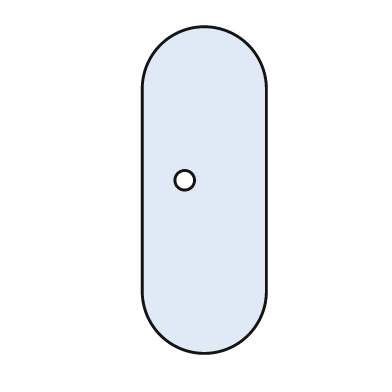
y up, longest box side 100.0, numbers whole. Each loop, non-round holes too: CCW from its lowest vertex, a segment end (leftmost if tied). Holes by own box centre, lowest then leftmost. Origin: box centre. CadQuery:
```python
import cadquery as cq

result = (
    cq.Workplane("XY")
    .moveTo(-19.0, -31.0)
    .threePointArc((0.0, -50.0), (19.0, -31.0))
    .lineTo(19.0, 31.0)
    .threePointArc((0.0, 50.0), (-19.0, 31.0))
    .close()
    .moveTo(-6.0, 3.0)
    .circle(3.0)
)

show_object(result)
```